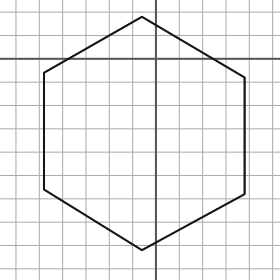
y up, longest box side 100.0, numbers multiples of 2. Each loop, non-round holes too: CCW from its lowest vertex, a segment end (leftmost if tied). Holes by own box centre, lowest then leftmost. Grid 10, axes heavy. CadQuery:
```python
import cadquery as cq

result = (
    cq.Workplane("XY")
    .moveTo(-6.0, -82.0)
    .lineTo(38.0, -58.0)
    .lineTo(38.0, -8.0)
    .lineTo(-6.0, 18.0)
    .lineTo(-48.0, -6.0)
    .lineTo(-48.0, -56.0)
    .close()
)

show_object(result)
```